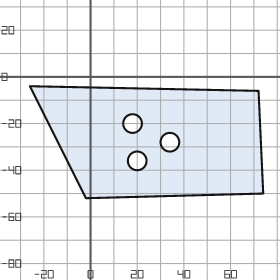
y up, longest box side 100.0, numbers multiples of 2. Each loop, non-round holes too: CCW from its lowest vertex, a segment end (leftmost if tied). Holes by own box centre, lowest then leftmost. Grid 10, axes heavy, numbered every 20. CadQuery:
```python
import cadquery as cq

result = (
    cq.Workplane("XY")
    .moveTo(-2.0, -52.0)
    .lineTo(74.0, -50.0)
    .lineTo(72.0, -6.0)
    .lineTo(-26.0, -4.0)
    .close()
    .moveTo(20.0, -36.0)
    .circle(4.0)
    .moveTo(34.0, -28.0)
    .circle(4.0)
    .moveTo(18.0, -20.0)
    .circle(4.0)
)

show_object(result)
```